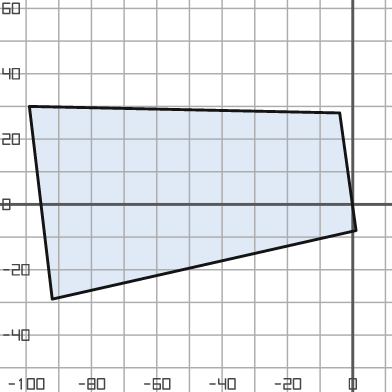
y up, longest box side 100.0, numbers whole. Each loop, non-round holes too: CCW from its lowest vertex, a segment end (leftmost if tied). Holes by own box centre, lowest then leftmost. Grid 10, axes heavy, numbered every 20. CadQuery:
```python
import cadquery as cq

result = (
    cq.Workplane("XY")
    .moveTo(-92.0, -29.0)
    .lineTo(1.0, -8.0)
    .lineTo(-4.0, 28.0)
    .lineTo(-99.0, 30.0)
    .close()
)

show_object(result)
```